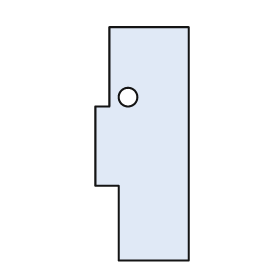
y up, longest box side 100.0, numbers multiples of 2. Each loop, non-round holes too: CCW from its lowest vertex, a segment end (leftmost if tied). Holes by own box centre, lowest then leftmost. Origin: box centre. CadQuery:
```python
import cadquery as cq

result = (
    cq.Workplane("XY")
    .moveTo(-10.0, -50.0)
    .lineTo(20.0, -50.0)
    .lineTo(20.0, 50.0)
    .lineTo(-14.0, 50.0)
    .lineTo(-14.0, 16.0)
    .lineTo(-20.0, 16.0)
    .lineTo(-20.0, -18.0)
    .lineTo(-10.0, -18.0)
    .close()
    .moveTo(-6.0, 20.0)
    .circle(4.0)
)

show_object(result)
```